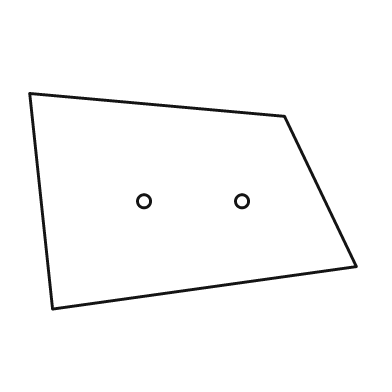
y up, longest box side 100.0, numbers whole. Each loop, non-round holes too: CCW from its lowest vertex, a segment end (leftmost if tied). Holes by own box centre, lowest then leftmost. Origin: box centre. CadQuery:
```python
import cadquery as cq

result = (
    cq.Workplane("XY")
    .moveTo(-43.0, -33.0)
    .lineTo(50.0, -20.0)
    .lineTo(28.0, 26.0)
    .lineTo(-50.0, 33.0)
    .close()
    .moveTo(-15.0, 0.0)
    .circle(2.0)
    .moveTo(15.0, 0.0)
    .circle(2.0)
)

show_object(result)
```